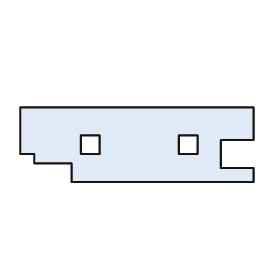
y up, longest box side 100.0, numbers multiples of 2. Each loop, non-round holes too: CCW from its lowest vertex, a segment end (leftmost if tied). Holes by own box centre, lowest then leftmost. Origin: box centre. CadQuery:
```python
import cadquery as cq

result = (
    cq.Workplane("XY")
    .moveTo(-28.0, -16.0)
    .lineTo(50.0, -16.0)
    .lineTo(50.0, -10.0)
    .lineTo(36.0, -10.0)
    .lineTo(36.0, 2.0)
    .lineTo(50.0, 2.0)
    .lineTo(50.0, 16.0)
    .lineTo(-50.0, 16.0)
    .lineTo(-50.0, -4.0)
    .lineTo(-44.0, -4.0)
    .lineTo(-44.0, -8.0)
    .lineTo(-28.0, -8.0)
    .close()
    .moveTo(-24.0, -4.0)
    .lineTo(-16.0, -4.0)
    .lineTo(-16.0, 4.0)
    .lineTo(-24.0, 4.0)
    .close()
    .moveTo(18.0, -4.0)
    .lineTo(26.0, -4.0)
    .lineTo(26.0, 4.0)
    .lineTo(18.0, 4.0)
    .close()
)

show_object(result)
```